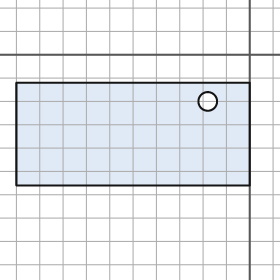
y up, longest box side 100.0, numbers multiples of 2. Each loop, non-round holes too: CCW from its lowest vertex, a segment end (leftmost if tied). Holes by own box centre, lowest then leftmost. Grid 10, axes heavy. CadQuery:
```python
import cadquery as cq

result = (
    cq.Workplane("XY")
    .moveTo(-100.0, -56.0)
    .lineTo(0.0, -56.0)
    .lineTo(0.0, -12.0)
    .lineTo(-100.0, -12.0)
    .close()
    .moveTo(-18.0, -20.0)
    .circle(4.0)
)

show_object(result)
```